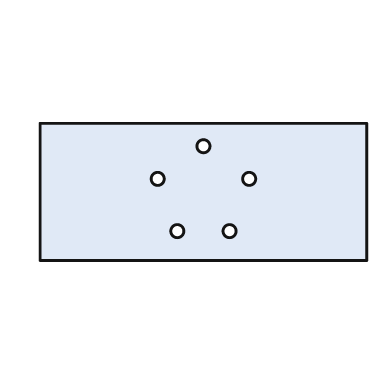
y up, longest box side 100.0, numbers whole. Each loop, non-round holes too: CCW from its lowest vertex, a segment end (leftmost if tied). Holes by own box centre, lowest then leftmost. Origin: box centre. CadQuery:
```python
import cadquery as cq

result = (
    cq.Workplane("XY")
    .moveTo(-50.0, -21.0)
    .lineTo(50.0, -21.0)
    .lineTo(50.0, 21.0)
    .lineTo(-50.0, 21.0)
    .close()
    .moveTo(-8.0, -12.0)
    .circle(2.0)
    .moveTo(8.0, -12.0)
    .circle(2.0)
    .moveTo(-14.0, 4.0)
    .circle(2.0)
    .moveTo(14.0, 4.0)
    .circle(2.0)
    .moveTo(0.0, 14.0)
    .circle(2.0)
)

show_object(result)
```